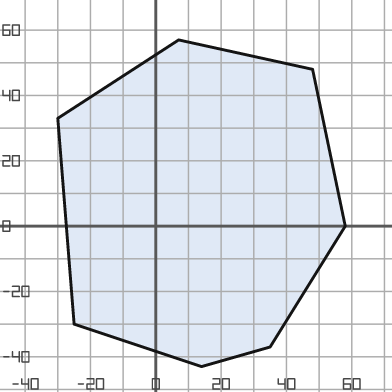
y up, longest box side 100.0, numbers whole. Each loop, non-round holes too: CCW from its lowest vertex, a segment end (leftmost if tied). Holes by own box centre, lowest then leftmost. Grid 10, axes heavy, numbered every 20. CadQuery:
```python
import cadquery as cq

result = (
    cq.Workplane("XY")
    .moveTo(14.0, -43.0)
    .lineTo(35.0, -37.0)
    .lineTo(58.0, 0.0)
    .lineTo(48.0, 48.0)
    .lineTo(7.0, 57.0)
    .lineTo(-30.0, 33.0)
    .lineTo(-25.0, -30.0)
    .close()
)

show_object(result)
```